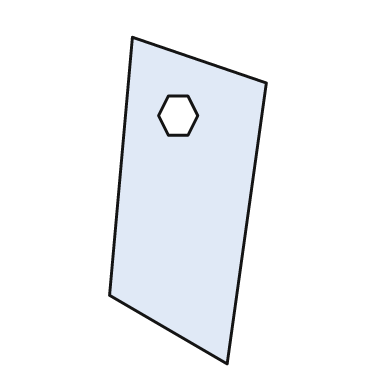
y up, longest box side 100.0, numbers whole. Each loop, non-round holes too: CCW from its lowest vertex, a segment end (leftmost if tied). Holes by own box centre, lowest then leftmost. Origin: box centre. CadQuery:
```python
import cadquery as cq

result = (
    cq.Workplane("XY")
    .moveTo(12.0, -50.0)
    .lineTo(24.0, 36.0)
    .lineTo(-17.0, 50.0)
    .lineTo(-24.0, -29.0)
    .close()
    .moveTo(-6.0, 20.0)
    .lineTo(0.0, 20.0)
    .lineTo(3.0, 26.0)
    .lineTo(0.0, 32.0)
    .lineTo(-6.0, 32.0)
    .lineTo(-9.0, 26.0)
    .close()
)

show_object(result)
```